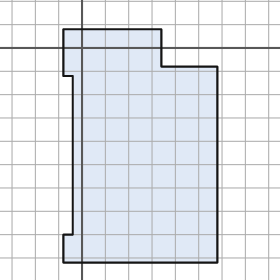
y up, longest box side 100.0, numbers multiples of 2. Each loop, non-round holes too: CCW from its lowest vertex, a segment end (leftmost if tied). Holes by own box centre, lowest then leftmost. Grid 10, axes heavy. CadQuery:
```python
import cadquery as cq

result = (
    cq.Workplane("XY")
    .moveTo(-8.0, -92.0)
    .lineTo(58.0, -92.0)
    .lineTo(58.0, -8.0)
    .lineTo(34.0, -8.0)
    .lineTo(34.0, 8.0)
    .lineTo(-8.0, 8.0)
    .lineTo(-8.0, -12.0)
    .lineTo(-4.0, -12.0)
    .lineTo(-4.0, -80.0)
    .lineTo(-8.0, -80.0)
    .close()
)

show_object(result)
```